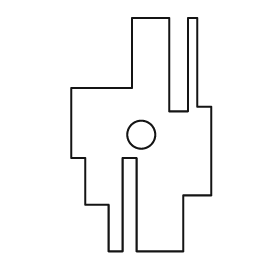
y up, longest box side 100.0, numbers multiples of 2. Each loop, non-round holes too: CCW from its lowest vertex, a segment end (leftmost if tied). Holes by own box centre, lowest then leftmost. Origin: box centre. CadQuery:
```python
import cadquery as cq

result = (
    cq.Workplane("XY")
    .moveTo(-14.0, -50.0)
    .lineTo(-8.0, -50.0)
    .lineTo(-8.0, -10.0)
    .lineTo(-2.0, -10.0)
    .lineTo(-2.0, -50.0)
    .lineTo(18.0, -50.0)
    .lineTo(18.0, -26.0)
    .lineTo(30.0, -26.0)
    .lineTo(30.0, 12.0)
    .lineTo(24.0, 12.0)
    .lineTo(24.0, 50.0)
    .lineTo(20.0, 50.0)
    .lineTo(20.0, 10.0)
    .lineTo(12.0, 10.0)
    .lineTo(12.0, 50.0)
    .lineTo(-4.0, 50.0)
    .lineTo(-4.0, 20.0)
    .lineTo(-30.0, 20.0)
    .lineTo(-30.0, -10.0)
    .lineTo(-24.0, -10.0)
    .lineTo(-24.0, -30.0)
    .lineTo(-14.0, -30.0)
    .close()
    .moveTo(0.0, 0.0)
    .circle(6.0)
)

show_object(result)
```